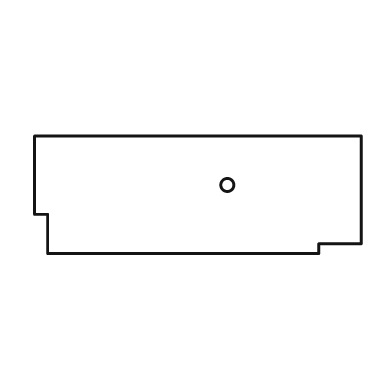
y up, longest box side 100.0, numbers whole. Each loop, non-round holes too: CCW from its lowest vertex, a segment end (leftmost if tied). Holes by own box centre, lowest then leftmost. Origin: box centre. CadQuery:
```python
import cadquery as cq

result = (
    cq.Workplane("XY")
    .moveTo(-46.0, -18.0)
    .lineTo(37.0, -18.0)
    .lineTo(37.0, -15.0)
    .lineTo(50.0, -15.0)
    .lineTo(50.0, 18.0)
    .lineTo(-50.0, 18.0)
    .lineTo(-50.0, -6.0)
    .lineTo(-46.0, -6.0)
    .close()
    .moveTo(9.0, 3.0)
    .circle(2.0)
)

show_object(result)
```